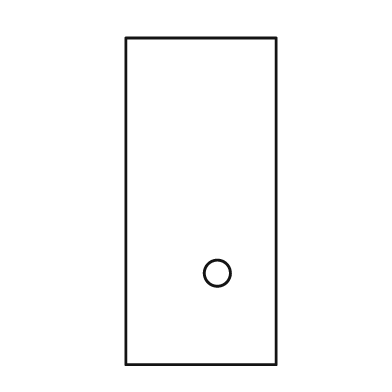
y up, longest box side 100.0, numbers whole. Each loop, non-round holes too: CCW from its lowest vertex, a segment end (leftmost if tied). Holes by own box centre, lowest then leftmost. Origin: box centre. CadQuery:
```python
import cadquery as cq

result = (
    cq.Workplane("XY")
    .moveTo(-23.0, -50.0)
    .lineTo(23.0, -50.0)
    .lineTo(23.0, 50.0)
    .lineTo(-23.0, 50.0)
    .close()
    .moveTo(5.0, -22.0)
    .circle(4.0)
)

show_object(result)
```